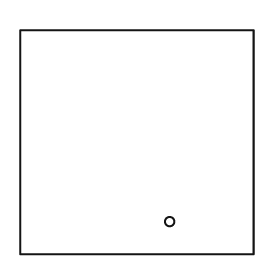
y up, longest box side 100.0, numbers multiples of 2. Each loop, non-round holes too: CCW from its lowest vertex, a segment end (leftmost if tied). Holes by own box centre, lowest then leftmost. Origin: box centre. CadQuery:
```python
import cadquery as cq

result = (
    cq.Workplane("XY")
    .moveTo(-50.0, -48.0)
    .lineTo(50.0, -48.0)
    .lineTo(50.0, 48.0)
    .lineTo(-50.0, 48.0)
    .close()
    .moveTo(14.0, -34.0)
    .circle(2.0)
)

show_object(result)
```